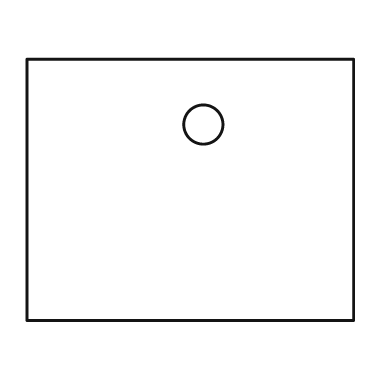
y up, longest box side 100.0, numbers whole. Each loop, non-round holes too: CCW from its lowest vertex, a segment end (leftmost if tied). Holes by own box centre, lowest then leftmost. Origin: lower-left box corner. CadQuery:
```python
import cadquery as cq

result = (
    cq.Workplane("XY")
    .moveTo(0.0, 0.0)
    .lineTo(100.0, 0.0)
    .lineTo(100.0, 80.0)
    .lineTo(0.0, 80.0)
    .close()
    .moveTo(54.0, 60.0)
    .circle(6.0)
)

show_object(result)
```